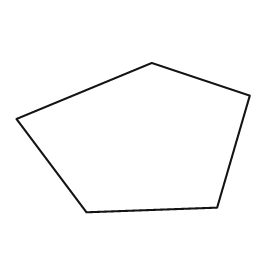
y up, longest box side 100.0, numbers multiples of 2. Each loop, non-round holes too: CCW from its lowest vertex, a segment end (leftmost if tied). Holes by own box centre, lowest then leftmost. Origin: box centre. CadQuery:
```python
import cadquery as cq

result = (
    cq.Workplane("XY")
    .moveTo(-20.0, -32.0)
    .lineTo(36.0, -30.0)
    .lineTo(50.0, 18.0)
    .lineTo(8.0, 32.0)
    .lineTo(-50.0, 8.0)
    .close()
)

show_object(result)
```